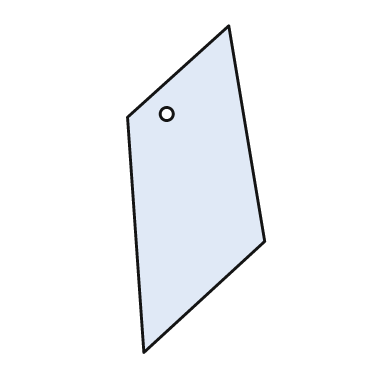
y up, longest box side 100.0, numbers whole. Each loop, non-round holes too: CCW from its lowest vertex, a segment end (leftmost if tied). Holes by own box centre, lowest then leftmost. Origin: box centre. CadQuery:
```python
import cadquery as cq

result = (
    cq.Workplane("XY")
    .moveTo(-16.0, -50.0)
    .lineTo(21.0, -16.0)
    .lineTo(10.0, 50.0)
    .lineTo(-21.0, 22.0)
    .close()
    .moveTo(-9.0, 23.0)
    .circle(2.0)
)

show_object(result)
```